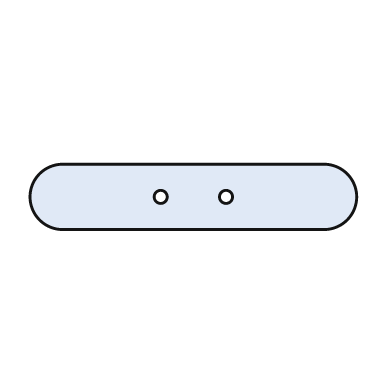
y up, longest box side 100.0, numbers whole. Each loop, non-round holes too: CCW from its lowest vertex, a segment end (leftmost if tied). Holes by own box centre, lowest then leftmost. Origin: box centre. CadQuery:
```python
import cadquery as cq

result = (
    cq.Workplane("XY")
    .moveTo(-40.0, -10.0)
    .lineTo(40.0, -10.0)
    .threePointArc((50.0, 0.0), (40.0, 10.0))
    .lineTo(-40.0, 10.0)
    .threePointArc((-50.0, 0.0), (-40.0, -10.0))
    .close()
    .moveTo(-10.0, 0.0)
    .circle(2.0)
    .moveTo(10.0, 0.0)
    .circle(2.0)
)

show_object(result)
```